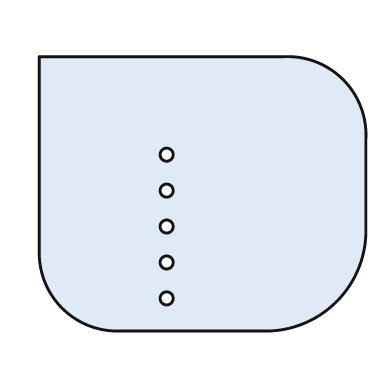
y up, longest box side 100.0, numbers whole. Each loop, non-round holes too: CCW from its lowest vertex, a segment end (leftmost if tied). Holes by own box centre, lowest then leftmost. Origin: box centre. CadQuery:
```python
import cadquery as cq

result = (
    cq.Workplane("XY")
    .moveTo(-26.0, -42.0)
    .lineTo(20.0, -42.0)
    .threePointArc((41.0, -33.0), (50.0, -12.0))
    .lineTo(50.0, 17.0)
    .threePointArc((43.0, 35.0), (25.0, 42.0))
    .lineTo(-50.0, 42.0)
    .lineTo(-50.0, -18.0)
    .threePointArc((-43.0, -35.0), (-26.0, -42.0))
    .close()
    .moveTo(-11.0, -32.0)
    .circle(2.0)
    .moveTo(-11.0, -21.0)
    .circle(2.0)
    .moveTo(-11.0, -10.0)
    .circle(2.0)
    .moveTo(-11.0, 1.0)
    .circle(2.0)
    .moveTo(-11.0, 12.0)
    .circle(2.0)
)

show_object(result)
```